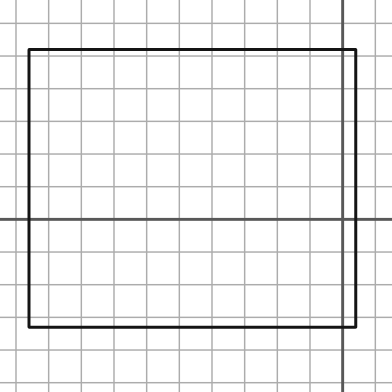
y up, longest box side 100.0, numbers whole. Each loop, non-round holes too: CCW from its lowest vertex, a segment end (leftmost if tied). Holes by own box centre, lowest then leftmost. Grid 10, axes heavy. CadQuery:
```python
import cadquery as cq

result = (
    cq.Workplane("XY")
    .moveTo(-96.0, -33.0)
    .lineTo(4.0, -33.0)
    .lineTo(4.0, 52.0)
    .lineTo(-96.0, 52.0)
    .close()
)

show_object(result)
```